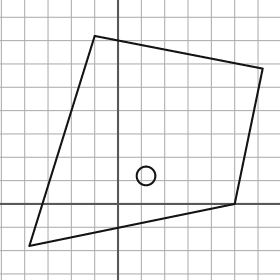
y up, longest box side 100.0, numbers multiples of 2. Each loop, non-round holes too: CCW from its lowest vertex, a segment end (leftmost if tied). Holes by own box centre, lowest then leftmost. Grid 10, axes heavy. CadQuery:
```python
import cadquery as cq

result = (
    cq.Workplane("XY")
    .moveTo(-38.0, -18.0)
    .lineTo(50.0, 0.0)
    .lineTo(62.0, 58.0)
    .lineTo(-10.0, 72.0)
    .close()
    .moveTo(12.0, 12.0)
    .circle(4.0)
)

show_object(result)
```